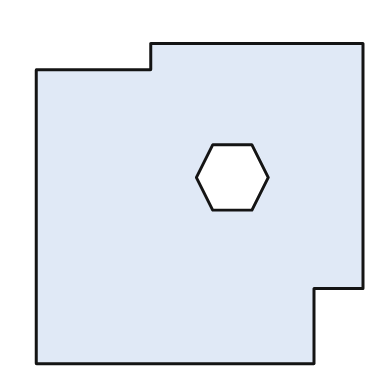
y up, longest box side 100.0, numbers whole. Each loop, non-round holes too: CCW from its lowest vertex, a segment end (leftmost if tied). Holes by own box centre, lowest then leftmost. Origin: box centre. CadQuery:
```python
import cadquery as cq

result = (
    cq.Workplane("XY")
    .moveTo(-50.0, -49.0)
    .lineTo(35.0, -49.0)
    .lineTo(35.0, -26.0)
    .lineTo(50.0, -26.0)
    .lineTo(50.0, 49.0)
    .lineTo(-15.0, 49.0)
    .lineTo(-15.0, 41.0)
    .lineTo(-50.0, 41.0)
    .close()
    .moveTo(4.0, -2.0)
    .lineTo(16.0, -2.0)
    .lineTo(21.0, 8.0)
    .lineTo(16.0, 18.0)
    .lineTo(4.0, 18.0)
    .lineTo(-1.0, 8.0)
    .close()
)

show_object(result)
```